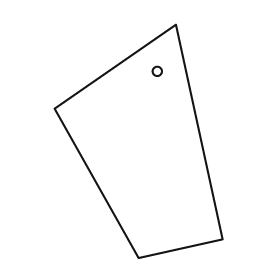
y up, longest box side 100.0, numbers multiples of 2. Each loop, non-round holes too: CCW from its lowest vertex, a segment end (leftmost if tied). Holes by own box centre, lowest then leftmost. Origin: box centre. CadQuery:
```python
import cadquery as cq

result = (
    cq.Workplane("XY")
    .moveTo(0.0, -50.0)
    .lineTo(36.0, -42.0)
    .lineTo(16.0, 50.0)
    .lineTo(-36.0, 14.0)
    .close()
    .moveTo(8.0, 30.0)
    .circle(2.0)
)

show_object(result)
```